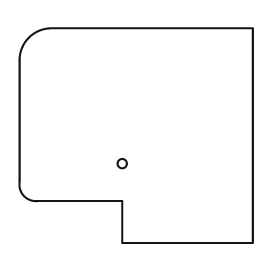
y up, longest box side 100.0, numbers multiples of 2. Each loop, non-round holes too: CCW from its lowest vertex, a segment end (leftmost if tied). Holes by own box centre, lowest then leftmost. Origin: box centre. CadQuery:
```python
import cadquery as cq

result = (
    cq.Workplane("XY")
    .moveTo(-6.0, -46.0)
    .lineTo(50.0, -46.0)
    .lineTo(50.0, 46.0)
    .lineTo(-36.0, 46.0)
    .threePointArc((-46.0, 42.0), (-50.0, 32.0))
    .lineTo(-50.0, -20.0)
    .threePointArc((-48.0, -26.0), (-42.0, -28.0))
    .lineTo(-6.0, -28.0)
    .close()
    .moveTo(-6.0, -12.0)
    .circle(2.0)
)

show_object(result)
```